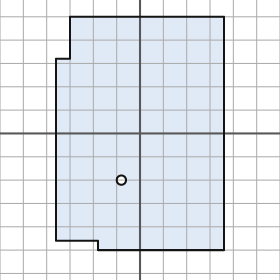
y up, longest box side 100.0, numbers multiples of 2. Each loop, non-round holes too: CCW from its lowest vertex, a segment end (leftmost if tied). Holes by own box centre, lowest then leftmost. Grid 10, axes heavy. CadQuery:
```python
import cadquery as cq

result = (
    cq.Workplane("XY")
    .moveTo(-18.0, -50.0)
    .lineTo(36.0, -50.0)
    .lineTo(36.0, 50.0)
    .lineTo(-30.0, 50.0)
    .lineTo(-30.0, 32.0)
    .lineTo(-36.0, 32.0)
    .lineTo(-36.0, -46.0)
    .lineTo(-18.0, -46.0)
    .close()
    .moveTo(-8.0, -20.0)
    .circle(2.0)
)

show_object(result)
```